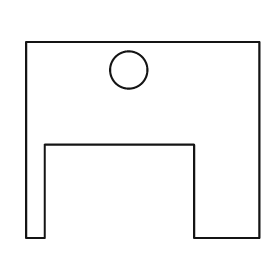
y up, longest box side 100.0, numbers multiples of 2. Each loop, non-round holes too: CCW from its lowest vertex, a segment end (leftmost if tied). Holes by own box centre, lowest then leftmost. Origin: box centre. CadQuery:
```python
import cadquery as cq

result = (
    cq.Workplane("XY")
    .moveTo(-50.0, -42.0)
    .lineTo(-42.0, -42.0)
    .lineTo(-42.0, -2.0)
    .lineTo(22.0, -2.0)
    .lineTo(22.0, -42.0)
    .lineTo(50.0, -42.0)
    .lineTo(50.0, 42.0)
    .lineTo(-50.0, 42.0)
    .close()
    .moveTo(-6.0, 30.0)
    .circle(8.0)
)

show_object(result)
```